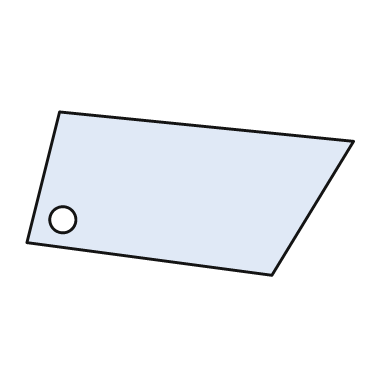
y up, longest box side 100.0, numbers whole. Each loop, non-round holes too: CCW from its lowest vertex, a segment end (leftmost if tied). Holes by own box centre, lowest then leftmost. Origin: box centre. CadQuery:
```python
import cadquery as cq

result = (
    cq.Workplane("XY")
    .moveTo(25.0, -25.0)
    .lineTo(50.0, 16.0)
    .lineTo(-40.0, 25.0)
    .lineTo(-50.0, -15.0)
    .close()
    .moveTo(-39.0, -8.0)
    .circle(4.0)
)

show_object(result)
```